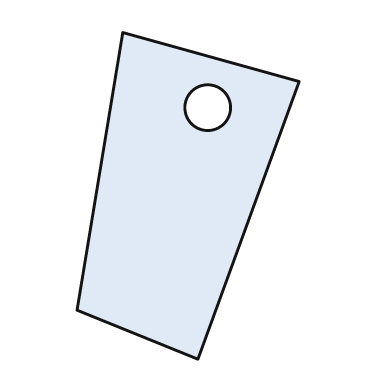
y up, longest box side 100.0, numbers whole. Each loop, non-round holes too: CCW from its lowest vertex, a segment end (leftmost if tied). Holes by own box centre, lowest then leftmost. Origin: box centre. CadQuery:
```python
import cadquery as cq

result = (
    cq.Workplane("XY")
    .moveTo(3.0, -50.0)
    .lineTo(34.0, 35.0)
    .lineTo(-20.0, 50.0)
    .lineTo(-34.0, -35.0)
    .close()
    .moveTo(6.0, 27.0)
    .circle(7.0)
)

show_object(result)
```